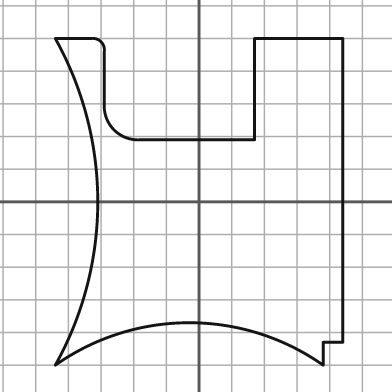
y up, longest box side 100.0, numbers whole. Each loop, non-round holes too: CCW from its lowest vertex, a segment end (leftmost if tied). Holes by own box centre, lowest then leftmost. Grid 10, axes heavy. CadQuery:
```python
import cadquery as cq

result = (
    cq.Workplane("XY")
    .moveTo(-44.0, -50.0)
    .threePointArc((-3.0, -37.0), (38.0, -50.0))
    .lineTo(38.0, -43.0)
    .lineTo(44.0, -43.0)
    .lineTo(44.0, 50.0)
    .lineTo(17.0, 50.0)
    .lineTo(17.0, 19.0)
    .lineTo(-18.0, 19.0)
    .threePointArc((-26.0, 22.0), (-29.0, 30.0))
    .lineTo(-29.0, 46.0)
    .threePointArc((-30.0, 49.0), (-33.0, 50.0))
    .lineTo(-44.0, 50.0)
    .threePointArc((-31.0, 0.0), (-44.0, -50.0))
    .close()
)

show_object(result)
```